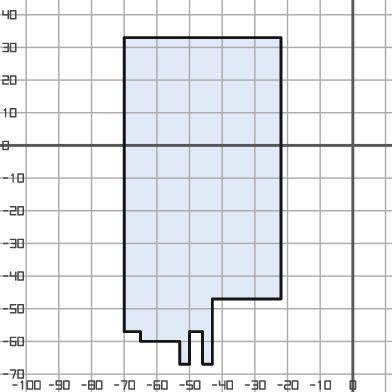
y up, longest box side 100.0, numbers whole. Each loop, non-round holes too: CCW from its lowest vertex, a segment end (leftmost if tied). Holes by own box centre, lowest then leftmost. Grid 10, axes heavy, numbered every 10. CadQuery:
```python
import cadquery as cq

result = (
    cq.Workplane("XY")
    .moveTo(-53.0, -67.0)
    .lineTo(-50.0, -67.0)
    .lineTo(-50.0, -57.0)
    .lineTo(-46.0, -57.0)
    .lineTo(-46.0, -67.0)
    .lineTo(-43.0, -67.0)
    .lineTo(-43.0, -47.0)
    .lineTo(-22.0, -47.0)
    .lineTo(-22.0, 33.0)
    .lineTo(-70.0, 33.0)
    .lineTo(-70.0, -57.0)
    .lineTo(-65.0, -57.0)
    .lineTo(-65.0, -60.0)
    .lineTo(-53.0, -60.0)
    .close()
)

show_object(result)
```